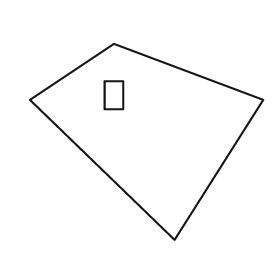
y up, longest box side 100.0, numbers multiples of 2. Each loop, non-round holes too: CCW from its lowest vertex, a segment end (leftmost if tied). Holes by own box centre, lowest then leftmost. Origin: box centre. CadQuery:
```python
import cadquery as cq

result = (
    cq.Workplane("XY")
    .moveTo(12.0, -42.0)
    .lineTo(50.0, 18.0)
    .lineTo(-14.0, 42.0)
    .lineTo(-50.0, 18.0)
    .close()
    .moveTo(-18.0, 14.0)
    .lineTo(-10.0, 14.0)
    .lineTo(-10.0, 26.0)
    .lineTo(-18.0, 26.0)
    .close()
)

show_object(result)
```